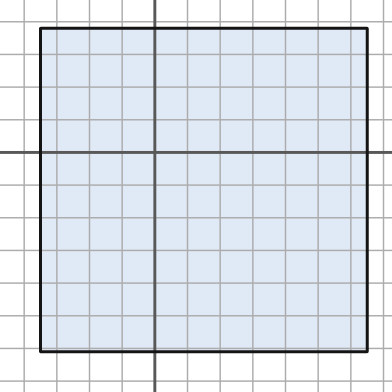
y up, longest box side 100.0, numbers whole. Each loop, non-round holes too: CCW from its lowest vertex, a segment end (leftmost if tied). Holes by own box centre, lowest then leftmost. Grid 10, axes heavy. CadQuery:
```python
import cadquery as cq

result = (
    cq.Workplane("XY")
    .moveTo(-35.0, -61.0)
    .lineTo(65.0, -61.0)
    .lineTo(65.0, 38.0)
    .lineTo(-35.0, 38.0)
    .close()
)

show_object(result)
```